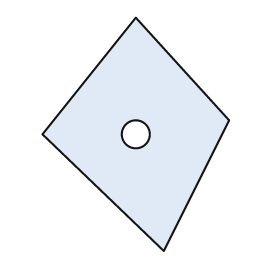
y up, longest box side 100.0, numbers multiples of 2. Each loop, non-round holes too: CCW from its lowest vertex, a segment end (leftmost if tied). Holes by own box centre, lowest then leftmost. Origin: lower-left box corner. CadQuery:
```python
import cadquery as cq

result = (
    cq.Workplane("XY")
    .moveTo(52.0, 0.0)
    .lineTo(80.0, 56.0)
    .lineTo(40.0, 100.0)
    .lineTo(0.0, 50.0)
    .close()
    .moveTo(40.0, 50.0)
    .circle(6.0)
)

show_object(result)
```